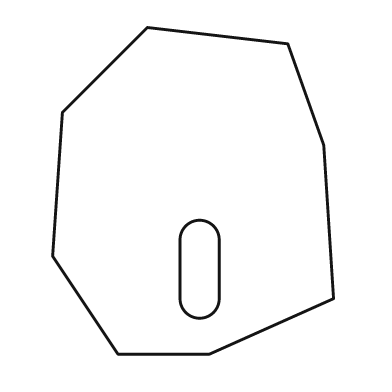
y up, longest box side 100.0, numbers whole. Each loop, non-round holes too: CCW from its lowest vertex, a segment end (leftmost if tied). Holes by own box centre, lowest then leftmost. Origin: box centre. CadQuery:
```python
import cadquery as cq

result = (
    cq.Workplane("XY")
    .moveTo(-23.0, -50.0)
    .lineTo(5.0, -50.0)
    .lineTo(43.0, -33.0)
    .lineTo(40.0, 14.0)
    .lineTo(29.0, 45.0)
    .lineTo(-14.0, 50.0)
    .lineTo(-40.0, 24.0)
    .lineTo(-43.0, -20.0)
    .close()
    .moveTo(-4.0, -33.0)
    .threePointArc((2.0, -39.0), (8.0, -33.0))
    .lineTo(8.0, -15.0)
    .threePointArc((2.0, -9.0), (-4.0, -15.0))
    .close()
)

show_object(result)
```